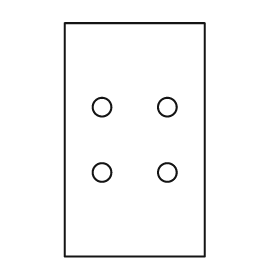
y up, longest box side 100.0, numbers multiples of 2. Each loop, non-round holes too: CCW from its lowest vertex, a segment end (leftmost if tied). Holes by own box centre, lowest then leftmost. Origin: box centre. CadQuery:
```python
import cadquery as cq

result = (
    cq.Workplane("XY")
    .moveTo(-30.0, -50.0)
    .lineTo(30.0, -50.0)
    .lineTo(30.0, 50.0)
    .lineTo(-30.0, 50.0)
    .close()
    .moveTo(-14.0, -14.0)
    .circle(4.0)
    .moveTo(14.0, -14.0)
    .circle(4.0)
    .moveTo(-14.0, 14.0)
    .circle(4.0)
    .moveTo(14.0, 14.0)
    .circle(4.0)
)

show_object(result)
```